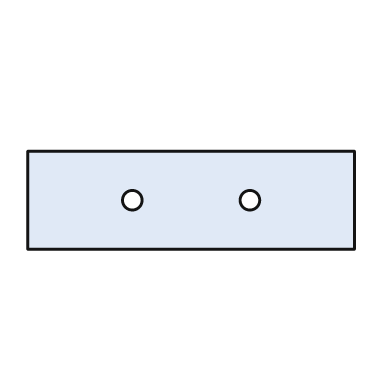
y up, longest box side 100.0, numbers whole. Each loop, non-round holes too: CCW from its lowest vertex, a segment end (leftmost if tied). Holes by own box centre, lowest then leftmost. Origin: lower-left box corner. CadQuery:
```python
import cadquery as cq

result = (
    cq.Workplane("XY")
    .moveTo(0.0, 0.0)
    .lineTo(100.0, 0.0)
    .lineTo(100.0, 30.0)
    .lineTo(0.0, 30.0)
    .close()
    .moveTo(32.0, 15.0)
    .circle(3.0)
    .moveTo(68.0, 15.0)
    .circle(3.0)
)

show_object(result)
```